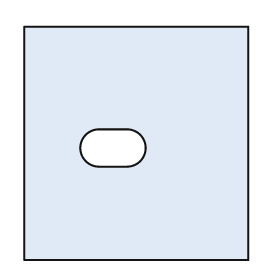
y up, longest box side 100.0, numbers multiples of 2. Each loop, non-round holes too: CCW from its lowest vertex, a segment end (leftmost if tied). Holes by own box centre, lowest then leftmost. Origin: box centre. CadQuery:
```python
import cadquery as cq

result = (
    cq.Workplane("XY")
    .moveTo(-48.0, -50.0)
    .lineTo(48.0, -50.0)
    .lineTo(48.0, 50.0)
    .lineTo(-48.0, 50.0)
    .close()
    .moveTo(-16.0, -10.0)
    .lineTo(-4.0, -10.0)
    .threePointArc((4.0, -2.0), (-4.0, 6.0))
    .lineTo(-16.0, 6.0)
    .threePointArc((-24.0, -2.0), (-16.0, -10.0))
    .close()
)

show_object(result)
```